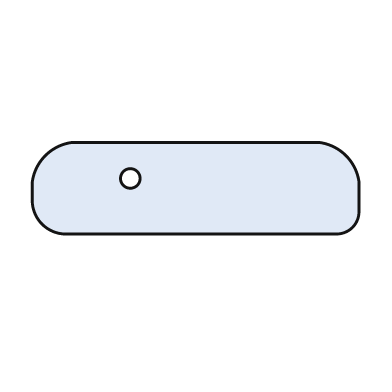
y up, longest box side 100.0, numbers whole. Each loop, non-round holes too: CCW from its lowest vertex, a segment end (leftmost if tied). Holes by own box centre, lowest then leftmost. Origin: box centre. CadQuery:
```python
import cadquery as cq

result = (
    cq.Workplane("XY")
    .moveTo(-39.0, -14.0)
    .lineTo(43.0, -14.0)
    .threePointArc((48.0, -12.0), (50.0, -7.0))
    .lineTo(50.0, 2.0)
    .threePointArc((46.0, 10.0), (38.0, 14.0))
    .lineTo(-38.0, 14.0)
    .threePointArc((-46.0, 10.0), (-50.0, 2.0))
    .lineTo(-50.0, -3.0)
    .threePointArc((-47.0, -11.0), (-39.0, -14.0))
    .close()
    .moveTo(-20.0, 3.0)
    .circle(3.0)
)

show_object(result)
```